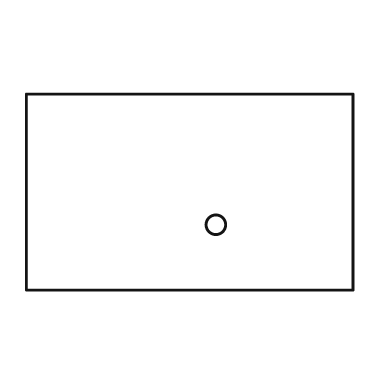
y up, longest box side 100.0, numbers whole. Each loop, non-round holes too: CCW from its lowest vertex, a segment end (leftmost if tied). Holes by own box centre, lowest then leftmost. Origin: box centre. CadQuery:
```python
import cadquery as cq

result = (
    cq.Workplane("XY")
    .moveTo(-50.0, -30.0)
    .lineTo(50.0, -30.0)
    .lineTo(50.0, 30.0)
    .lineTo(-50.0, 30.0)
    .close()
    .moveTo(8.0, -10.0)
    .circle(3.0)
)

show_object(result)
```